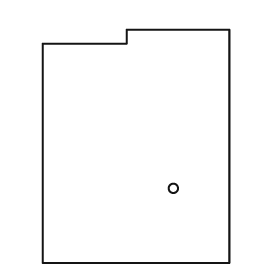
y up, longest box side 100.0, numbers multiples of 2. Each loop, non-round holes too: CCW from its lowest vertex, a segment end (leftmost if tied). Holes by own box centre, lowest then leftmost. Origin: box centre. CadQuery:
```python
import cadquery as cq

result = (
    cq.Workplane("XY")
    .moveTo(-40.0, -50.0)
    .lineTo(40.0, -50.0)
    .lineTo(40.0, 50.0)
    .lineTo(-4.0, 50.0)
    .lineTo(-4.0, 44.0)
    .lineTo(-40.0, 44.0)
    .close()
    .moveTo(16.0, -18.0)
    .circle(2.0)
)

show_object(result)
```